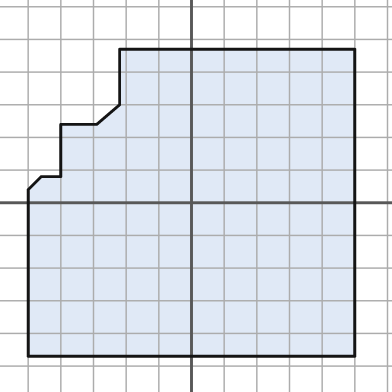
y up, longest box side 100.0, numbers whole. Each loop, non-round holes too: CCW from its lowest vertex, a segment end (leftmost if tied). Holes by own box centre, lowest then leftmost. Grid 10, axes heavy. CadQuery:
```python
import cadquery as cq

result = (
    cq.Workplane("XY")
    .moveTo(-50.0, -47.0)
    .lineTo(50.0, -47.0)
    .lineTo(50.0, 47.0)
    .lineTo(-22.0, 47.0)
    .lineTo(-22.0, 30.0)
    .lineTo(-29.0, 24.0)
    .lineTo(-40.0, 24.0)
    .lineTo(-40.0, 8.0)
    .lineTo(-46.0, 8.0)
    .lineTo(-50.0, 4.0)
    .close()
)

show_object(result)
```